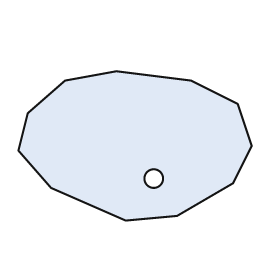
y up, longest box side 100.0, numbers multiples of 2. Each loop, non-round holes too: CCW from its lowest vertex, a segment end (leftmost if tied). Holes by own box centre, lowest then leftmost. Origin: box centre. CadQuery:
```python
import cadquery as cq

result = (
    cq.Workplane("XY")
    .moveTo(-4.0, -32.0)
    .lineTo(18.0, -30.0)
    .lineTo(42.0, -16.0)
    .lineTo(50.0, 0.0)
    .lineTo(44.0, 18.0)
    .lineTo(24.0, 28.0)
    .lineTo(-8.0, 32.0)
    .lineTo(-30.0, 28.0)
    .lineTo(-46.0, 14.0)
    .lineTo(-50.0, -2.0)
    .lineTo(-36.0, -18.0)
    .close()
    .moveTo(8.0, -14.0)
    .circle(4.0)
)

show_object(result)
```